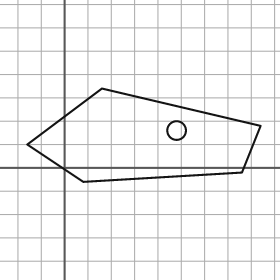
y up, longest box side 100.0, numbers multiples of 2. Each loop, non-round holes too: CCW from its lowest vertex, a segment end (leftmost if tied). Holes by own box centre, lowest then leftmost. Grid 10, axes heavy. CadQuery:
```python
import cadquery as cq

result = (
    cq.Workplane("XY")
    .moveTo(8.0, -6.0)
    .lineTo(76.0, -2.0)
    .lineTo(84.0, 18.0)
    .lineTo(16.0, 34.0)
    .lineTo(-16.0, 10.0)
    .close()
    .moveTo(48.0, 16.0)
    .circle(4.0)
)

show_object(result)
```